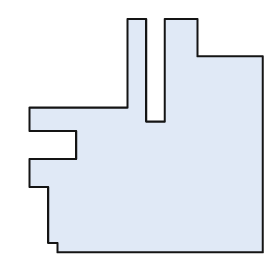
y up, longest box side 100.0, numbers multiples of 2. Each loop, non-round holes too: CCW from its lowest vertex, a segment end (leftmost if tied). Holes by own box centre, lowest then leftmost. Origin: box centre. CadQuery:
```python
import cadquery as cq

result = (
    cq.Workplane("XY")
    .moveTo(-38.0, -50.0)
    .lineTo(50.0, -50.0)
    .lineTo(50.0, 34.0)
    .lineTo(22.0, 34.0)
    .lineTo(22.0, 50.0)
    .lineTo(8.0, 50.0)
    .lineTo(8.0, 6.0)
    .lineTo(0.0, 6.0)
    .lineTo(0.0, 50.0)
    .lineTo(-8.0, 50.0)
    .lineTo(-8.0, 12.0)
    .lineTo(-50.0, 12.0)
    .lineTo(-50.0, 2.0)
    .lineTo(-30.0, 2.0)
    .lineTo(-30.0, -10.0)
    .lineTo(-50.0, -10.0)
    .lineTo(-50.0, -22.0)
    .lineTo(-42.0, -22.0)
    .lineTo(-42.0, -46.0)
    .lineTo(-38.0, -46.0)
    .close()
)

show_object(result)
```